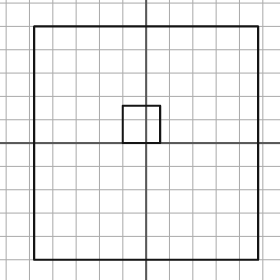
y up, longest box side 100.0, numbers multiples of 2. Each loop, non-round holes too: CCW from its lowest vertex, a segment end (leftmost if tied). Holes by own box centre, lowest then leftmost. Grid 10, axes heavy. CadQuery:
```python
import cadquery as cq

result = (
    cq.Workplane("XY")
    .moveTo(-48.0, -50.0)
    .lineTo(48.0, -50.0)
    .lineTo(48.0, 50.0)
    .lineTo(-48.0, 50.0)
    .close()
    .moveTo(-10.0, 0.0)
    .lineTo(6.0, 0.0)
    .lineTo(6.0, 16.0)
    .lineTo(-10.0, 16.0)
    .close()
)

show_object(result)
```